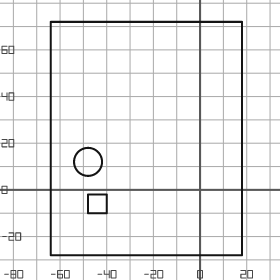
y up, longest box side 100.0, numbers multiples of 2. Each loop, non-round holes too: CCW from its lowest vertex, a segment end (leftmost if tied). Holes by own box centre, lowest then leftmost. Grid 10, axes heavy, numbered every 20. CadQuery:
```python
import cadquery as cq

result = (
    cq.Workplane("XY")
    .moveTo(-64.0, -28.0)
    .lineTo(18.0, -28.0)
    .lineTo(18.0, 72.0)
    .lineTo(-64.0, 72.0)
    .close()
    .moveTo(-48.0, -10.0)
    .lineTo(-40.0, -10.0)
    .lineTo(-40.0, -2.0)
    .lineTo(-48.0, -2.0)
    .close()
    .moveTo(-48.0, 12.0)
    .circle(6.0)
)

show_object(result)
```